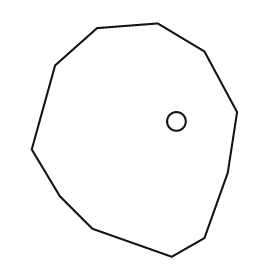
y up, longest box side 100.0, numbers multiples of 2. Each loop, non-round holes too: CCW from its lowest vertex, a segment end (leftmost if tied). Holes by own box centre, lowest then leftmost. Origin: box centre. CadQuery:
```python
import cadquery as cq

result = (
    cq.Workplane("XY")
    .moveTo(16.0, -50.0)
    .lineTo(30.0, -42.0)
    .lineTo(40.0, -14.0)
    .lineTo(44.0, 12.0)
    .lineTo(30.0, 38.0)
    .lineTo(10.0, 50.0)
    .lineTo(-16.0, 48.0)
    .lineTo(-34.0, 32.0)
    .lineTo(-44.0, -4.0)
    .lineTo(-32.0, -24.0)
    .lineTo(-18.0, -38.0)
    .close()
    .moveTo(18.0, 8.0)
    .circle(4.0)
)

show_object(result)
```